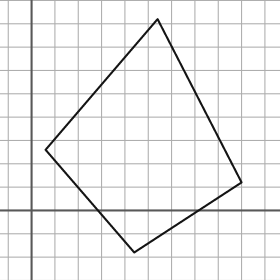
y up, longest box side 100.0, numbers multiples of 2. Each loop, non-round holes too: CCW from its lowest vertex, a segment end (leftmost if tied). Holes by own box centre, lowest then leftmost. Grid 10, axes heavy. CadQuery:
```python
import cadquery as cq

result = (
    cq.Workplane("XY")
    .moveTo(44.0, -18.0)
    .lineTo(90.0, 12.0)
    .lineTo(54.0, 82.0)
    .lineTo(6.0, 26.0)
    .close()
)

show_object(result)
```